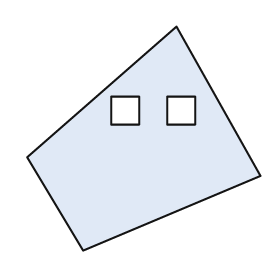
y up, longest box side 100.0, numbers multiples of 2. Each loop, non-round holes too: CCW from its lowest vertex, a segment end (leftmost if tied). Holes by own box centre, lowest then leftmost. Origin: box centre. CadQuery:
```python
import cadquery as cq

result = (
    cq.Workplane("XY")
    .moveTo(-26.0, -48.0)
    .lineTo(50.0, -16.0)
    .lineTo(14.0, 48.0)
    .lineTo(-50.0, -8.0)
    .close()
    .moveTo(-14.0, 6.0)
    .lineTo(-2.0, 6.0)
    .lineTo(-2.0, 18.0)
    .lineTo(-14.0, 18.0)
    .close()
    .moveTo(10.0, 6.0)
    .lineTo(22.0, 6.0)
    .lineTo(22.0, 18.0)
    .lineTo(10.0, 18.0)
    .close()
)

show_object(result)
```